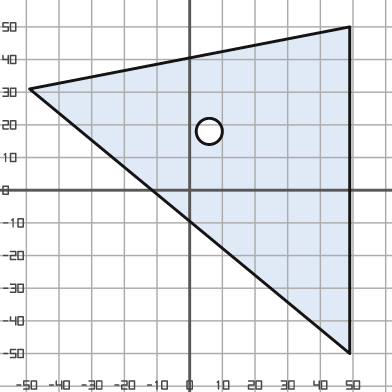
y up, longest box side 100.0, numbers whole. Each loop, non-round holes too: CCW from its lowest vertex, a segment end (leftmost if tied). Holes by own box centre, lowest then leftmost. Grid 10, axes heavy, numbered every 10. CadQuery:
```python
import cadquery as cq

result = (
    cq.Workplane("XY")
    .moveTo(49.0, -50.0)
    .lineTo(49.0, 50.0)
    .lineTo(-49.0, 31.0)
    .close()
    .moveTo(6.0, 18.0)
    .circle(4.0)
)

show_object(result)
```